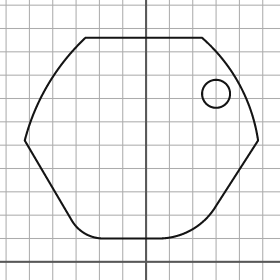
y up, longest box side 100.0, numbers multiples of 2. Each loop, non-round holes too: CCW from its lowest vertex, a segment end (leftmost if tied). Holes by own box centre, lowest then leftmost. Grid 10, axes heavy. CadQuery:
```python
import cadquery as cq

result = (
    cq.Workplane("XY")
    .moveTo(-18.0, 10.0)
    .lineTo(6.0, 10.0)
    .threePointArc((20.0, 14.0), (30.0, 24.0))
    .lineTo(48.0, 52.0)
    .threePointArc((40.0, 76.0), (24.0, 96.0))
    .lineTo(-26.0, 96.0)
    .threePointArc((-42.0, 76.0), (-52.0, 52.0))
    .lineTo(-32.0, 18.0)
    .threePointArc((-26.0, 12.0), (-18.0, 10.0))
    .close()
    .moveTo(30.0, 72.0)
    .circle(6.0)
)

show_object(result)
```